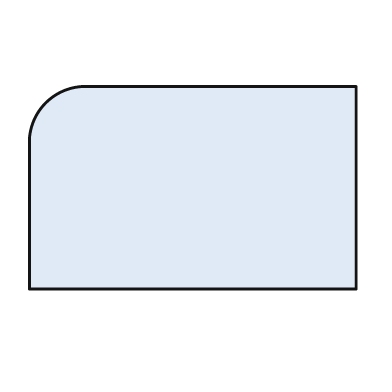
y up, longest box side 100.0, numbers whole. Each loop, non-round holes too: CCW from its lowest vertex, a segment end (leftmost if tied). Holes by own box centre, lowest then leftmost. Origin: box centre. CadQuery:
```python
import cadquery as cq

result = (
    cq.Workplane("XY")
    .moveTo(-50.0, -31.0)
    .lineTo(50.0, -31.0)
    .lineTo(50.0, 31.0)
    .lineTo(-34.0, 31.0)
    .threePointArc((-45.0, 26.0), (-50.0, 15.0))
    .close()
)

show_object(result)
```